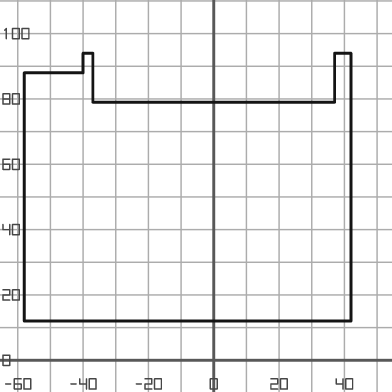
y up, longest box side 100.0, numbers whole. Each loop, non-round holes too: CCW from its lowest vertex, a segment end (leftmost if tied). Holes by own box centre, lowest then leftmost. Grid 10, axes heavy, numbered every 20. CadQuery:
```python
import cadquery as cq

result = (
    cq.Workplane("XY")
    .moveTo(-58.0, 12.0)
    .lineTo(42.0, 12.0)
    .lineTo(42.0, 94.0)
    .lineTo(37.0, 94.0)
    .lineTo(37.0, 79.0)
    .lineTo(-37.0, 79.0)
    .lineTo(-37.0, 94.0)
    .lineTo(-40.0, 94.0)
    .lineTo(-40.0, 88.0)
    .lineTo(-58.0, 88.0)
    .close()
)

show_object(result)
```